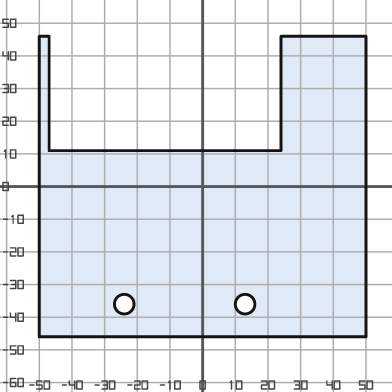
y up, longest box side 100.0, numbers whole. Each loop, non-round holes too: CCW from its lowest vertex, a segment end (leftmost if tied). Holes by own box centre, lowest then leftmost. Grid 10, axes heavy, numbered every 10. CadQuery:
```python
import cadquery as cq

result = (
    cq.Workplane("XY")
    .moveTo(-50.0, -46.0)
    .lineTo(50.0, -46.0)
    .lineTo(50.0, 46.0)
    .lineTo(24.0, 46.0)
    .lineTo(24.0, 11.0)
    .lineTo(-47.0, 11.0)
    .lineTo(-47.0, 46.0)
    .lineTo(-50.0, 46.0)
    .close()
    .moveTo(-24.0, -36.0)
    .circle(3.0)
    .moveTo(13.0, -36.0)
    .circle(3.0)
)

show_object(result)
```